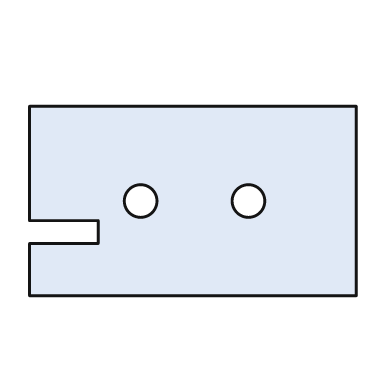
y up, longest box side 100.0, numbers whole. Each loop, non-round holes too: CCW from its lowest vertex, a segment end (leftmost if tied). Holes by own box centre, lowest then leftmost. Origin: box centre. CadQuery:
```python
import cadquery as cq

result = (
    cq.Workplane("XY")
    .moveTo(-50.0, -29.0)
    .lineTo(50.0, -29.0)
    .lineTo(50.0, 29.0)
    .lineTo(-50.0, 29.0)
    .lineTo(-50.0, -6.0)
    .lineTo(-29.0, -6.0)
    .lineTo(-29.0, -13.0)
    .lineTo(-50.0, -13.0)
    .close()
    .moveTo(-16.0, 0.0)
    .circle(5.0)
    .moveTo(17.0, 0.0)
    .circle(5.0)
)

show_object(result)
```